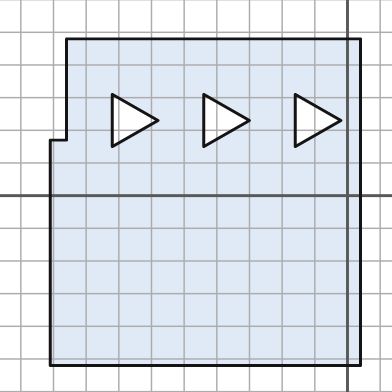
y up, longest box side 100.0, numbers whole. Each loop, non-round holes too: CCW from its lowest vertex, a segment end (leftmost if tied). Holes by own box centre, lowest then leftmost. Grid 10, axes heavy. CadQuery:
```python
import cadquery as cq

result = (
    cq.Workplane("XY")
    .moveTo(-91.0, -52.0)
    .lineTo(4.0, -52.0)
    .lineTo(4.0, 48.0)
    .lineTo(-86.0, 48.0)
    .lineTo(-86.0, 17.0)
    .lineTo(-91.0, 17.0)
    .close()
    .moveTo(-72.0, 15.0)
    .lineTo(-58.0, 23.0)
    .lineTo(-72.0, 31.0)
    .close()
    .moveTo(-44.0, 15.0)
    .lineTo(-30.0, 23.0)
    .lineTo(-44.0, 31.0)
    .close()
    .moveTo(-16.0, 15.0)
    .lineTo(-2.0, 23.0)
    .lineTo(-16.0, 31.0)
    .close()
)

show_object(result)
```